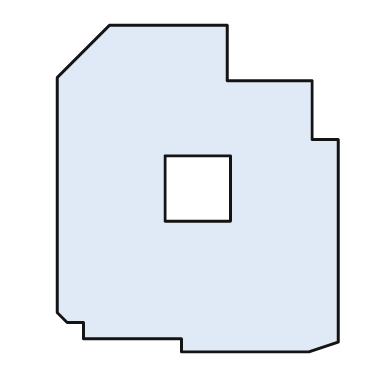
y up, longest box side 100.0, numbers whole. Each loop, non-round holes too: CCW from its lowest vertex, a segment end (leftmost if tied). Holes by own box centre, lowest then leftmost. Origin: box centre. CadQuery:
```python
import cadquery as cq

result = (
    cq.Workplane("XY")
    .moveTo(-5.0, -50.0)
    .lineTo(34.0, -50.0)
    .lineTo(43.0, -47.0)
    .lineTo(43.0, 15.0)
    .lineTo(35.0, 15.0)
    .lineTo(35.0, 33.0)
    .lineTo(9.0, 33.0)
    .lineTo(9.0, 50.0)
    .lineTo(-27.0, 50.0)
    .lineTo(-43.0, 34.0)
    .lineTo(-43.0, -38.0)
    .lineTo(-40.0, -41.0)
    .lineTo(-35.0, -41.0)
    .lineTo(-35.0, -46.0)
    .lineTo(-5.0, -46.0)
    .close()
    .moveTo(-10.0, -10.0)
    .lineTo(10.0, -10.0)
    .lineTo(10.0, 10.0)
    .lineTo(-10.0, 10.0)
    .close()
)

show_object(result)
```